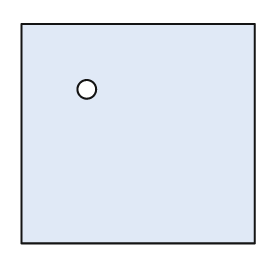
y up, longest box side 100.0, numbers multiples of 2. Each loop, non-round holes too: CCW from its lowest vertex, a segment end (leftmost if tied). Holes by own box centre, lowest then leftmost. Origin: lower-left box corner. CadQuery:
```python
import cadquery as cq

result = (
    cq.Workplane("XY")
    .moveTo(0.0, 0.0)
    .lineTo(100.0, 0.0)
    .lineTo(100.0, 94.0)
    .lineTo(0.0, 94.0)
    .close()
    .moveTo(28.0, 66.0)
    .circle(4.0)
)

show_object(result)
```